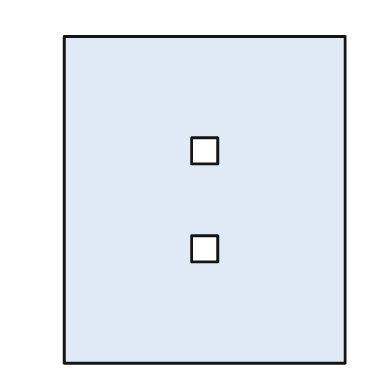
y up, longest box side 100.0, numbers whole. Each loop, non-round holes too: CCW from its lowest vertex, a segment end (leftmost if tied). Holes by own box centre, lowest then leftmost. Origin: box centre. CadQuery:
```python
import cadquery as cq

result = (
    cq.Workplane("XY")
    .moveTo(-43.0, -50.0)
    .lineTo(43.0, -50.0)
    .lineTo(43.0, 50.0)
    .lineTo(-43.0, 50.0)
    .close()
    .moveTo(-4.0, -19.0)
    .lineTo(4.0, -19.0)
    .lineTo(4.0, -11.0)
    .lineTo(-4.0, -11.0)
    .close()
    .moveTo(-4.0, 11.0)
    .lineTo(4.0, 11.0)
    .lineTo(4.0, 19.0)
    .lineTo(-4.0, 19.0)
    .close()
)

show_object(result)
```